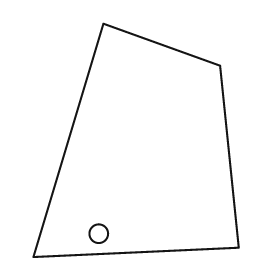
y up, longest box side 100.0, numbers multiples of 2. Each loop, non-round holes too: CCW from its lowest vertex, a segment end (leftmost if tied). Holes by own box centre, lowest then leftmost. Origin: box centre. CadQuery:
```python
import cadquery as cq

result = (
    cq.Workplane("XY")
    .moveTo(-44.0, -50.0)
    .lineTo(44.0, -46.0)
    .lineTo(36.0, 32.0)
    .lineTo(-14.0, 50.0)
    .close()
    .moveTo(-16.0, -40.0)
    .circle(4.0)
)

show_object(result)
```